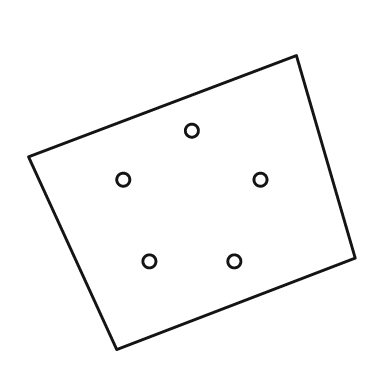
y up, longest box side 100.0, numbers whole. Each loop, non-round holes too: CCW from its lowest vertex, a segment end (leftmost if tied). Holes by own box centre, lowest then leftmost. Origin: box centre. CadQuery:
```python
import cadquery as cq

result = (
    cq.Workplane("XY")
    .moveTo(-23.0, -45.0)
    .lineTo(50.0, -17.0)
    .lineTo(32.0, 45.0)
    .lineTo(-50.0, 14.0)
    .close()
    .moveTo(-13.0, -18.0)
    .circle(2.0)
    .moveTo(13.0, -18.0)
    .circle(2.0)
    .moveTo(-21.0, 7.0)
    .circle(2.0)
    .moveTo(21.0, 7.0)
    .circle(2.0)
    .moveTo(0.0, 22.0)
    .circle(2.0)
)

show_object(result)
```